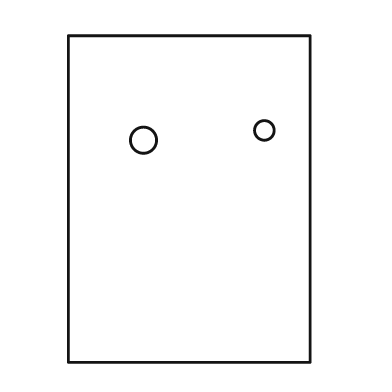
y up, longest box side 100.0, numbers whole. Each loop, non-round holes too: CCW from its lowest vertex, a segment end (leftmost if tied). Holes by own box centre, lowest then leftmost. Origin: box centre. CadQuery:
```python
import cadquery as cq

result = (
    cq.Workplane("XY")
    .moveTo(-37.0, -50.0)
    .lineTo(37.0, -50.0)
    .lineTo(37.0, 50.0)
    .lineTo(-37.0, 50.0)
    .close()
    .moveTo(-14.0, 18.0)
    .circle(4.0)
    .moveTo(23.0, 21.0)
    .circle(3.0)
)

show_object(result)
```